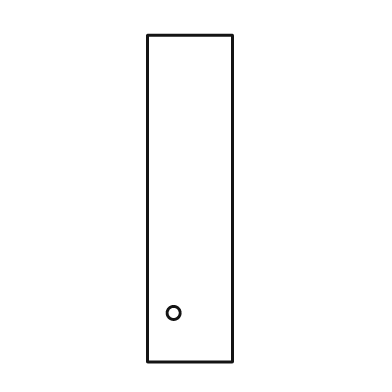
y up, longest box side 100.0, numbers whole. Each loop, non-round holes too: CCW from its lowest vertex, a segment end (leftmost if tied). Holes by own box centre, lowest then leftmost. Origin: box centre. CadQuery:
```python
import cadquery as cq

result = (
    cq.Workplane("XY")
    .moveTo(-13.0, -50.0)
    .lineTo(13.0, -50.0)
    .lineTo(13.0, 50.0)
    .lineTo(-13.0, 50.0)
    .close()
    .moveTo(-5.0, -35.0)
    .circle(2.0)
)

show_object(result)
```